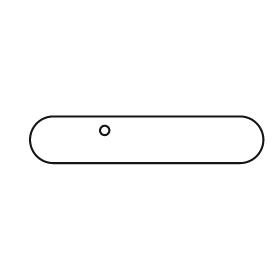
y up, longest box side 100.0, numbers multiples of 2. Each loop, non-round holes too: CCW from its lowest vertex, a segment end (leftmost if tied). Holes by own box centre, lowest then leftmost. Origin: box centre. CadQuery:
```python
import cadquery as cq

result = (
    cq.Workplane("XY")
    .moveTo(-40.0, -10.0)
    .lineTo(40.0, -10.0)
    .threePointArc((50.0, 0.0), (40.0, 10.0))
    .lineTo(-40.0, 10.0)
    .threePointArc((-50.0, 0.0), (-40.0, -10.0))
    .close()
    .moveTo(-18.0, 4.0)
    .circle(2.0)
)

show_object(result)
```